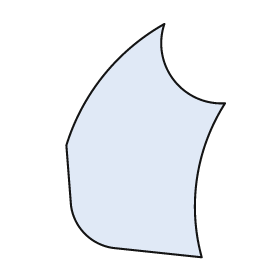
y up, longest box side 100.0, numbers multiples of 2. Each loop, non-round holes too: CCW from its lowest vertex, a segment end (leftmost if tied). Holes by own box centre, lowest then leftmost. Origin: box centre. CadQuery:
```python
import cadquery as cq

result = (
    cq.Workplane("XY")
    .moveTo(24.0, -50.0)
    .threePointArc((22.0, -16.0), (34.0, 16.0))
    .threePointArc((12.0, 26.0), (8.0, 50.0))
    .threePointArc((-18.0, 28.0), (-34.0, -2.0))
    .lineTo(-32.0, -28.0)
    .threePointArc((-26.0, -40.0), (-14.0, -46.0))
    .close()
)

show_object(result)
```